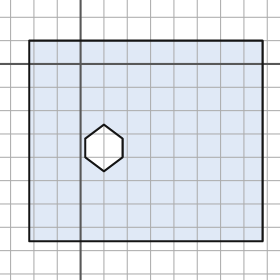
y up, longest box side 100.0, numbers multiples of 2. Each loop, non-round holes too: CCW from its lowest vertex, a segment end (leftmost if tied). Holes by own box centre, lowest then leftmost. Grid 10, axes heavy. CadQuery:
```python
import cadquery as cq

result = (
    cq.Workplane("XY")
    .moveTo(-22.0, -76.0)
    .lineTo(78.0, -76.0)
    .lineTo(78.0, 10.0)
    .lineTo(-22.0, 10.0)
    .close()
    .moveTo(10.0, -46.0)
    .lineTo(18.0, -40.0)
    .lineTo(18.0, -32.0)
    .lineTo(10.0, -26.0)
    .lineTo(2.0, -32.0)
    .lineTo(2.0, -40.0)
    .close()
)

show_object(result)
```